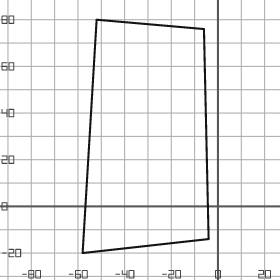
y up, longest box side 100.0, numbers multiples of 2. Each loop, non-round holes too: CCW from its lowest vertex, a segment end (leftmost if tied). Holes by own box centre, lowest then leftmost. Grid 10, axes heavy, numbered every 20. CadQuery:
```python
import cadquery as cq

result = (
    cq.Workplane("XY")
    .moveTo(-58.0, -20.0)
    .lineTo(-4.0, -14.0)
    .lineTo(-6.0, 76.0)
    .lineTo(-52.0, 80.0)
    .close()
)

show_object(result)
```